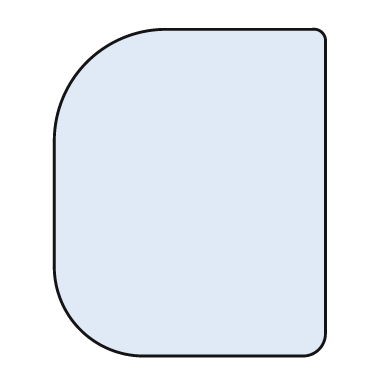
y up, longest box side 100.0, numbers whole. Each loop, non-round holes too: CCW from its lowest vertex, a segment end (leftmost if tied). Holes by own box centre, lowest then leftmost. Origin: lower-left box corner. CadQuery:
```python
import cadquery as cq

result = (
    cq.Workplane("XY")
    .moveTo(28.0, 0.0)
    .lineTo(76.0, 0.0)
    .threePointArc((81.0, 2.0), (83.0, 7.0))
    .lineTo(83.0, 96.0)
    .threePointArc((82.0, 99.0), (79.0, 100.0))
    .lineTo(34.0, 100.0)
    .threePointArc((10.0, 90.0), (0.0, 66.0))
    .lineTo(0.0, 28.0)
    .threePointArc((8.0, 8.0), (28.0, 0.0))
    .close()
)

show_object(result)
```